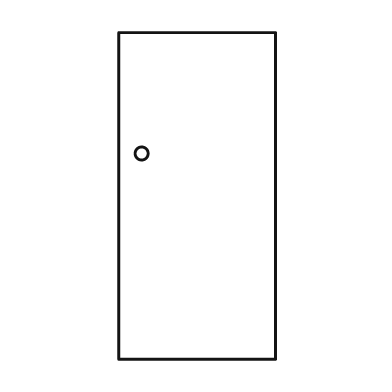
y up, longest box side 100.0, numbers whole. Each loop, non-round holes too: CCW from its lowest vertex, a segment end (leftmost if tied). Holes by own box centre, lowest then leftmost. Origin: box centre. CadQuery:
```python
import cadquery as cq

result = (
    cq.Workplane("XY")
    .moveTo(-24.0, -50.0)
    .lineTo(24.0, -50.0)
    .lineTo(24.0, 50.0)
    .lineTo(-24.0, 50.0)
    .close()
    .moveTo(-17.0, 13.0)
    .circle(2.0)
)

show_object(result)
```